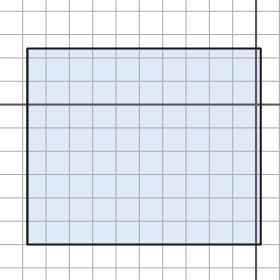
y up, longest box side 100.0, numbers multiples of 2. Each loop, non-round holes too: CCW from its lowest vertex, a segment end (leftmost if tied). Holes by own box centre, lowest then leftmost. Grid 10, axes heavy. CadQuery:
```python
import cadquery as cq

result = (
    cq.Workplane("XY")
    .moveTo(-98.0, -60.0)
    .lineTo(2.0, -60.0)
    .lineTo(2.0, 24.0)
    .lineTo(-98.0, 24.0)
    .close()
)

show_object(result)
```